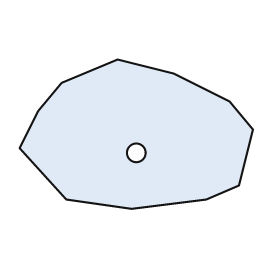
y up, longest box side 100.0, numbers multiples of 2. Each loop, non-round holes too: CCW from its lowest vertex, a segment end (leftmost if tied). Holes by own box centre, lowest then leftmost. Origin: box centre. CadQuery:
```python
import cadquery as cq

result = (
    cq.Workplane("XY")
    .moveTo(-2.0, -32.0)
    .lineTo(30.0, -28.0)
    .lineTo(44.0, -22.0)
    .lineTo(50.0, 2.0)
    .lineTo(40.0, 14.0)
    .lineTo(16.0, 26.0)
    .lineTo(-8.0, 32.0)
    .lineTo(-32.0, 22.0)
    .lineTo(-42.0, 10.0)
    .lineTo(-50.0, -6.0)
    .lineTo(-30.0, -28.0)
    .close()
    .moveTo(0.0, -8.0)
    .circle(4.0)
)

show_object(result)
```